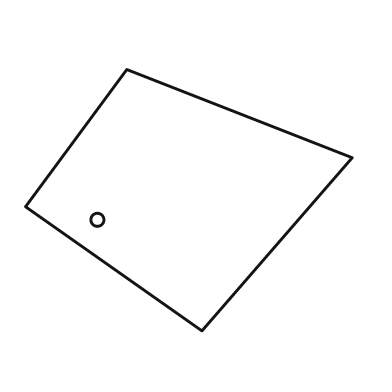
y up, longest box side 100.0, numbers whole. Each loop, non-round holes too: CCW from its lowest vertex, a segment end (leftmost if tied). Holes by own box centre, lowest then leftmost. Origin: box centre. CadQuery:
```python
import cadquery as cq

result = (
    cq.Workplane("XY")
    .moveTo(4.0, -40.0)
    .lineTo(50.0, 13.0)
    .lineTo(-19.0, 40.0)
    .lineTo(-50.0, -2.0)
    .close()
    .moveTo(-28.0, -6.0)
    .circle(2.0)
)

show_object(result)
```